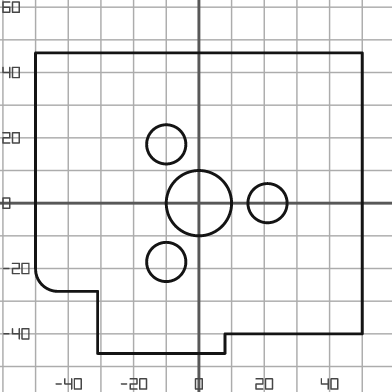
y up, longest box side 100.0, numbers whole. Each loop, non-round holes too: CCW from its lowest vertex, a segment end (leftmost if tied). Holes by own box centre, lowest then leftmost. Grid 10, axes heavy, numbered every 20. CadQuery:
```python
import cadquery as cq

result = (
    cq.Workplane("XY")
    .moveTo(-31.0, -46.0)
    .lineTo(8.0, -46.0)
    .lineTo(8.0, -40.0)
    .lineTo(50.0, -40.0)
    .lineTo(50.0, 46.0)
    .lineTo(-50.0, 46.0)
    .lineTo(-50.0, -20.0)
    .threePointArc((-48.0, -25.0), (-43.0, -27.0))
    .lineTo(-31.0, -27.0)
    .close()
    .moveTo(-10.0, -18.0)
    .circle(6.0)
    .moveTo(0.0, 0.0)
    .circle(10.0)
    .moveTo(21.0, 0.0)
    .circle(6.0)
    .moveTo(-10.0, 18.0)
    .circle(6.0)
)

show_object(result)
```